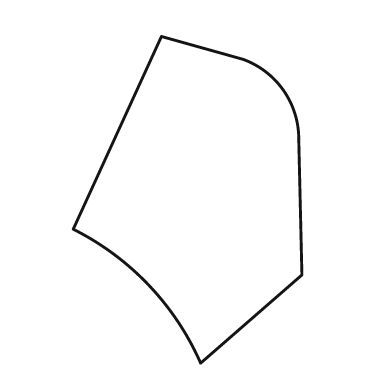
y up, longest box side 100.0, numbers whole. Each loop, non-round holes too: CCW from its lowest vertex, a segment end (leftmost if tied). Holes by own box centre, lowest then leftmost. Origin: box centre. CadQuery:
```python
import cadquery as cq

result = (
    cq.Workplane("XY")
    .moveTo(4.0, -50.0)
    .lineTo(35.0, -23.0)
    .lineTo(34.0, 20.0)
    .threePointArc((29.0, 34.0), (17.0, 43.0))
    .lineTo(-8.0, 50.0)
    .lineTo(-35.0, -9.0)
    .threePointArc((-12.0, -26.0), (4.0, -50.0))
    .close()
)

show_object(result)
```